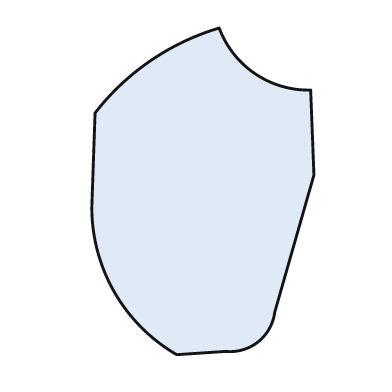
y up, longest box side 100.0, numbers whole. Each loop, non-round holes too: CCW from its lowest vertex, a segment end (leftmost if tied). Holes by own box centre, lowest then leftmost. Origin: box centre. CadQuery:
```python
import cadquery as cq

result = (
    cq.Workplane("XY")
    .moveTo(-8.0, -50.0)
    .lineTo(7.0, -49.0)
    .threePointArc((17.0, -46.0), (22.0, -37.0))
    .lineTo(34.0, 5.0)
    .lineTo(33.0, 31.0)
    .threePointArc((16.0, 36.0), (5.0, 50.0))
    .threePointArc((-16.0, 40.0), (-33.0, 24.0))
    .lineTo(-34.0, -5.0)
    .threePointArc((-27.0, -31.0), (-8.0, -50.0))
    .close()
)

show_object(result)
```